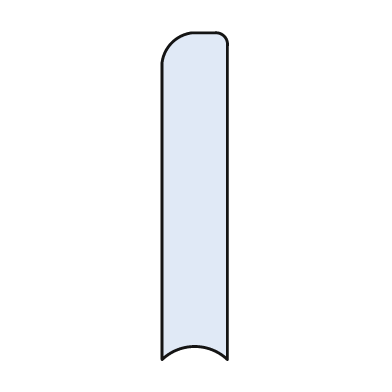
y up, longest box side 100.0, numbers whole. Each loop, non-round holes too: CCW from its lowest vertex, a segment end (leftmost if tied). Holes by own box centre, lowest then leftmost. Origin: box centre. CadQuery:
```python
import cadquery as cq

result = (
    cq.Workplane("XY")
    .moveTo(-10.0, -50.0)
    .threePointArc((0.0, -46.0), (10.0, -50.0))
    .lineTo(10.0, 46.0)
    .threePointArc((9.0, 49.0), (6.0, 50.0))
    .lineTo(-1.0, 50.0)
    .threePointArc((-7.0, 47.0), (-10.0, 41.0))
    .close()
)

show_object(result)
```